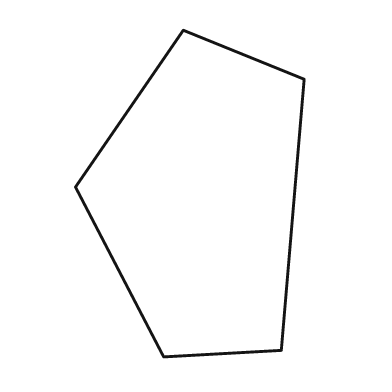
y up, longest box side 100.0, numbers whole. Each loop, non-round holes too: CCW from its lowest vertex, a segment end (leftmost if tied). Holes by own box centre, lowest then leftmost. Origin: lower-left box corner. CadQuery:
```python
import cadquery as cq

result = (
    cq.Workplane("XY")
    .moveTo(27.0, 0.0)
    .lineTo(63.0, 2.0)
    .lineTo(70.0, 85.0)
    .lineTo(33.0, 100.0)
    .lineTo(0.0, 52.0)
    .close()
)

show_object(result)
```